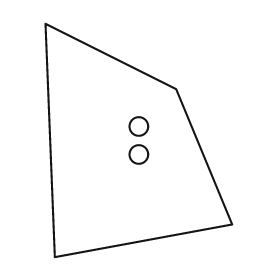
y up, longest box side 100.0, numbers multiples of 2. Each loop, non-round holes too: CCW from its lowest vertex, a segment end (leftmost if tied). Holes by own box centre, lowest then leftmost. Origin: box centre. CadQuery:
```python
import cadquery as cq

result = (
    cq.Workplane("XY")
    .moveTo(-36.0, -50.0)
    .lineTo(40.0, -36.0)
    .lineTo(16.0, 22.0)
    .lineTo(-40.0, 50.0)
    .close()
    .moveTo(0.0, -6.0)
    .circle(4.0)
    .moveTo(0.0, 6.0)
    .circle(4.0)
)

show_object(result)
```